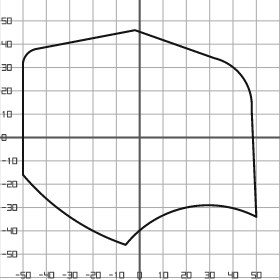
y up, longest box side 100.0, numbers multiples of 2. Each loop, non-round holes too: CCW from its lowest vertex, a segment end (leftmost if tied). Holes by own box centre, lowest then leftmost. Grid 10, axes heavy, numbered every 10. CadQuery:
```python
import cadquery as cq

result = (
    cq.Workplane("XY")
    .moveTo(-6.0, -46.0)
    .threePointArc((20.0, -30.0), (50.0, -34.0))
    .lineTo(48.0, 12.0)
    .threePointArc((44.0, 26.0), (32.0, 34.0))
    .lineTo(-2.0, 46.0)
    .lineTo(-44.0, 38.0)
    .threePointArc((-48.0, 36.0), (-50.0, 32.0))
    .lineTo(-50.0, -16.0)
    .threePointArc((-30.0, -34.0), (-6.0, -46.0))
    .close()
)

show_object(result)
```